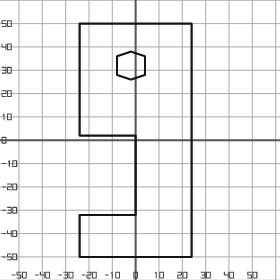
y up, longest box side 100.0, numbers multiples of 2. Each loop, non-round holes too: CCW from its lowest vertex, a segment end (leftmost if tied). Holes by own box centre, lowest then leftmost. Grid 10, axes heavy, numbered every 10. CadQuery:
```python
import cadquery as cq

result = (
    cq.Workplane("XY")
    .moveTo(-24.0, -50.0)
    .lineTo(24.0, -50.0)
    .lineTo(24.0, 50.0)
    .lineTo(-24.0, 50.0)
    .lineTo(-24.0, 2.0)
    .lineTo(0.0, 2.0)
    .lineTo(0.0, -32.0)
    .lineTo(-24.0, -32.0)
    .close()
    .moveTo(-2.0, 26.0)
    .lineTo(4.0, 28.0)
    .lineTo(4.0, 36.0)
    .lineTo(-2.0, 38.0)
    .lineTo(-8.0, 36.0)
    .lineTo(-8.0, 28.0)
    .close()
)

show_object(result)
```